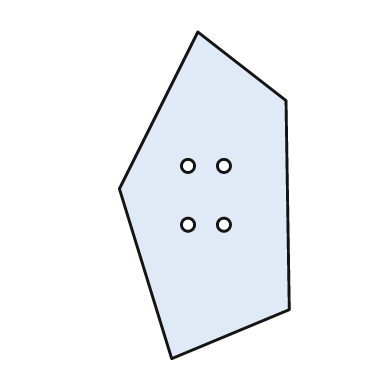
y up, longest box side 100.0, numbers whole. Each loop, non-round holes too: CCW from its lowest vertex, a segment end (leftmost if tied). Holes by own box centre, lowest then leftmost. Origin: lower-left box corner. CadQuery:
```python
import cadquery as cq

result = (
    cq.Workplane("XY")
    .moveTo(16.0, 0.0)
    .lineTo(52.0, 15.0)
    .lineTo(51.0, 79.0)
    .lineTo(24.0, 100.0)
    .lineTo(0.0, 52.0)
    .close()
    .moveTo(21.0, 41.0)
    .circle(2.0)
    .moveTo(32.0, 41.0)
    .circle(2.0)
    .moveTo(21.0, 59.0)
    .circle(2.0)
    .moveTo(32.0, 59.0)
    .circle(2.0)
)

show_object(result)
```